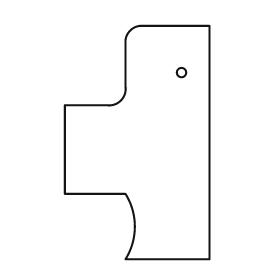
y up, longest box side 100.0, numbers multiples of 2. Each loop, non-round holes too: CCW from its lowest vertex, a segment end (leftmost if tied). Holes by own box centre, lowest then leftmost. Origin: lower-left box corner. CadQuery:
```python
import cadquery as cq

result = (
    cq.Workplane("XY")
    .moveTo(26.0, 0.0)
    .lineTo(62.0, 0.0)
    .lineTo(62.0, 100.0)
    .lineTo(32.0, 100.0)
    .threePointArc((28.0, 98.0), (26.0, 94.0))
    .lineTo(26.0, 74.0)
    .threePointArc((24.0, 68.0), (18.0, 66.0))
    .lineTo(0.0, 66.0)
    .lineTo(0.0, 28.0)
    .lineTo(26.0, 28.0)
    .threePointArc((30.0, 14.0), (26.0, 0.0))
    .close()
    .moveTo(50.0, 80.0)
    .circle(2.0)
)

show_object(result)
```